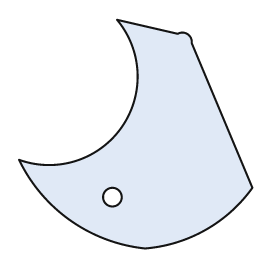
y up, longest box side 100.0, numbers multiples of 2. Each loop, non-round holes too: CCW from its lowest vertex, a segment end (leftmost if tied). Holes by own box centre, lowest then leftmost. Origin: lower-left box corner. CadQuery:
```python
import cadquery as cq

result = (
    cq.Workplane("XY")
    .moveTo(54.0, 0.0)
    .threePointArc((80.0, 8.0), (100.0, 26.0))
    .lineTo(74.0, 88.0)
    .threePointArc((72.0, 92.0), (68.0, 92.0))
    .lineTo(42.0, 98.0)
    .threePointArc((44.0, 52.0), (0.0, 38.0))
    .threePointArc((22.0, 12.0), (54.0, 0.0))
    .close()
    .moveTo(40.0, 22.0)
    .circle(4.0)
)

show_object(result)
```